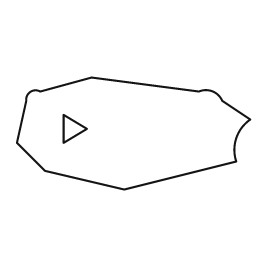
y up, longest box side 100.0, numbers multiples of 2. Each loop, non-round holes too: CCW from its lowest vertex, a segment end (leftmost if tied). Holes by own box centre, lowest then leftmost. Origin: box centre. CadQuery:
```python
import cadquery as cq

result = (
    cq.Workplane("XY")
    .moveTo(-4.0, -24.0)
    .lineTo(44.0, -12.0)
    .threePointArc((44.0, -2.0), (50.0, 6.0))
    .lineTo(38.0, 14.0)
    .threePointArc((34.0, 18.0), (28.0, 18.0))
    .lineTo(-18.0, 24.0)
    .lineTo(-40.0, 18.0)
    .threePointArc((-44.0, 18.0), (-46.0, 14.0))
    .lineTo(-50.0, -4.0)
    .lineTo(-38.0, -16.0)
    .close()
    .moveTo(-30.0, -4.0)
    .lineTo(-20.0, 2.0)
    .lineTo(-30.0, 8.0)
    .close()
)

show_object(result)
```